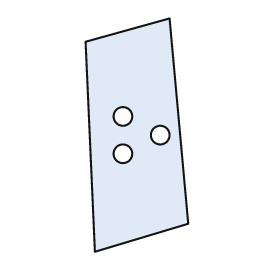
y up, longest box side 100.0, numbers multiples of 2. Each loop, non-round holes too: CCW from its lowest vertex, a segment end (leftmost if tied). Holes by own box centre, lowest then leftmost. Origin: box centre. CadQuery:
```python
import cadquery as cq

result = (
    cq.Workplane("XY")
    .moveTo(-18.0, -50.0)
    .lineTo(22.0, -38.0)
    .lineTo(14.0, 50.0)
    .lineTo(-22.0, 40.0)
    .close()
    .moveTo(-6.0, -8.0)
    .circle(4.0)
    .moveTo(10.0, 0.0)
    .circle(4.0)
    .moveTo(-6.0, 8.0)
    .circle(4.0)
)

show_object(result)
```